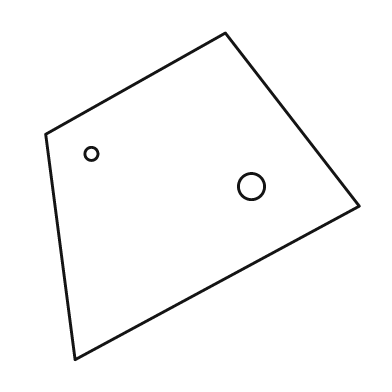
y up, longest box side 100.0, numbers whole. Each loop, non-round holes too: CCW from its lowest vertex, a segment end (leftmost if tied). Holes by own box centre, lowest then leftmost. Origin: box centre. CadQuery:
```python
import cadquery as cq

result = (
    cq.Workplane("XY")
    .moveTo(-39.0, -50.0)
    .lineTo(48.0, -3.0)
    .lineTo(7.0, 50.0)
    .lineTo(-48.0, 19.0)
    .close()
    .moveTo(15.0, 3.0)
    .circle(4.0)
    .moveTo(-34.0, 13.0)
    .circle(2.0)
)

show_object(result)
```